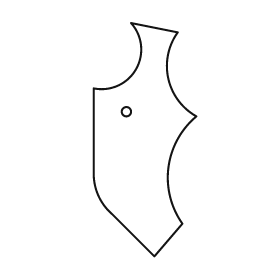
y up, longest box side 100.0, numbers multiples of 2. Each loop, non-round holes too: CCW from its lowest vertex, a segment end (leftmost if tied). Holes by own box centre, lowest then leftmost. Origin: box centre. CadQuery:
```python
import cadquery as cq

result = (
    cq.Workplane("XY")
    .moveTo(4.0, -50.0)
    .lineTo(16.0, -36.0)
    .threePointArc((10.0, -12.0), (22.0, 10.0))
    .threePointArc((10.0, 26.0), (14.0, 46.0))
    .lineTo(-6.0, 50.0)
    .threePointArc((-4.0, 30.0), (-22.0, 22.0))
    .lineTo(-22.0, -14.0)
    .threePointArc((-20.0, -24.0), (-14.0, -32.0))
    .close()
    .moveTo(-8.0, 12.0)
    .circle(2.0)
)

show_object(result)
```